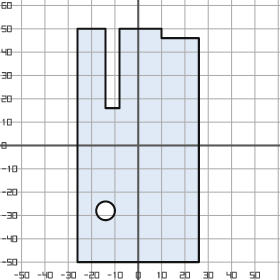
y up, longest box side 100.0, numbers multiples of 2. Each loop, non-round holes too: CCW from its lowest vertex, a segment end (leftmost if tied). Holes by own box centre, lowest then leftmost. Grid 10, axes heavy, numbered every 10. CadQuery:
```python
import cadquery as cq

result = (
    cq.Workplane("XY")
    .moveTo(-26.0, -50.0)
    .lineTo(26.0, -50.0)
    .lineTo(26.0, 46.0)
    .lineTo(10.0, 46.0)
    .lineTo(10.0, 50.0)
    .lineTo(-8.0, 50.0)
    .lineTo(-8.0, 16.0)
    .lineTo(-14.0, 16.0)
    .lineTo(-14.0, 50.0)
    .lineTo(-26.0, 50.0)
    .close()
    .moveTo(-14.0, -28.0)
    .circle(4.0)
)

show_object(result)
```